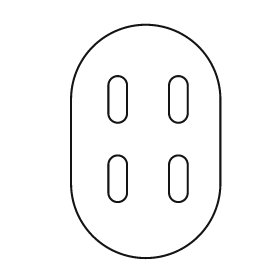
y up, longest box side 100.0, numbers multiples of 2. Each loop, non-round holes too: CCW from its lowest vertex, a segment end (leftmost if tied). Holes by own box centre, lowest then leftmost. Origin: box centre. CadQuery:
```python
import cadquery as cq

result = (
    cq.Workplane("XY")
    .moveTo(-32.0, -18.0)
    .threePointArc((0.0, -50.0), (32.0, -18.0))
    .lineTo(32.0, 18.0)
    .threePointArc((0.0, 50.0), (-32.0, 18.0))
    .close()
    .moveTo(-16.0, -22.0)
    .threePointArc((-12.0, -26.0), (-8.0, -22.0))
    .lineTo(-8.0, -10.0)
    .threePointArc((-12.0, -6.0), (-16.0, -10.0))
    .close()
    .moveTo(10.0, -22.0)
    .threePointArc((14.0, -26.0), (18.0, -22.0))
    .lineTo(18.0, -10.0)
    .threePointArc((14.0, -6.0), (10.0, -10.0))
    .close()
    .moveTo(-16.0, 12.0)
    .threePointArc((-12.0, 8.0), (-8.0, 12.0))
    .lineTo(-8.0, 24.0)
    .threePointArc((-12.0, 28.0), (-16.0, 24.0))
    .close()
    .moveTo(10.0, 12.0)
    .threePointArc((14.0, 8.0), (18.0, 12.0))
    .lineTo(18.0, 24.0)
    .threePointArc((14.0, 28.0), (10.0, 24.0))
    .close()
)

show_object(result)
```